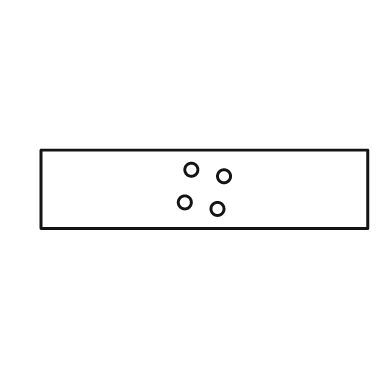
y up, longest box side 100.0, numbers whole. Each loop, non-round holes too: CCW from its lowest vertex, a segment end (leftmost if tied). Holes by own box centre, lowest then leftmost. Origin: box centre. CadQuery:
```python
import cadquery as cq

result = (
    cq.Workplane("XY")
    .moveTo(-50.0, -12.0)
    .lineTo(50.0, -12.0)
    .lineTo(50.0, 12.0)
    .lineTo(-50.0, 12.0)
    .close()
    .moveTo(4.0, -6.0)
    .circle(2.0)
    .moveTo(-6.0, -4.0)
    .circle(2.0)
    .moveTo(6.0, 4.0)
    .circle(2.0)
    .moveTo(-4.0, 6.0)
    .circle(2.0)
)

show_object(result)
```